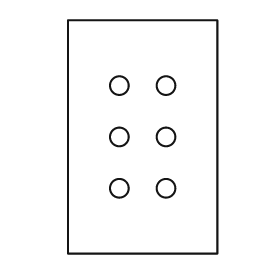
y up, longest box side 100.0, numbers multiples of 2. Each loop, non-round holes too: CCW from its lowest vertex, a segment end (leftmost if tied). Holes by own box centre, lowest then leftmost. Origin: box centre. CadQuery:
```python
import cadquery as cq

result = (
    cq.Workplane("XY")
    .moveTo(-32.0, -50.0)
    .lineTo(32.0, -50.0)
    .lineTo(32.0, 50.0)
    .lineTo(-32.0, 50.0)
    .close()
    .moveTo(-10.0, -22.0)
    .circle(4.0)
    .moveTo(10.0, -22.0)
    .circle(4.0)
    .moveTo(-10.0, 0.0)
    .circle(4.0)
    .moveTo(10.0, 0.0)
    .circle(4.0)
    .moveTo(-10.0, 22.0)
    .circle(4.0)
    .moveTo(10.0, 22.0)
    .circle(4.0)
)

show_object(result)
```